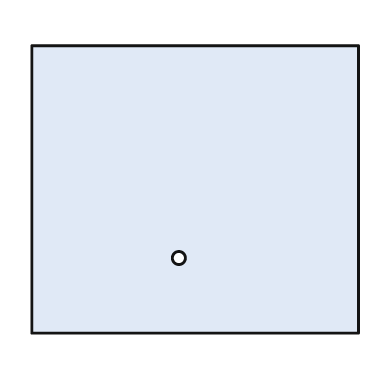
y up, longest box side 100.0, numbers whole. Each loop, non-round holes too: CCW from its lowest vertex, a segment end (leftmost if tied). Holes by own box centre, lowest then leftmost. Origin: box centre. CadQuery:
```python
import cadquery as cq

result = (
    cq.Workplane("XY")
    .moveTo(-50.0, -44.0)
    .lineTo(50.0, -44.0)
    .lineTo(50.0, 44.0)
    .lineTo(-50.0, 44.0)
    .close()
    .moveTo(-5.0, -21.0)
    .circle(2.0)
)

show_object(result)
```